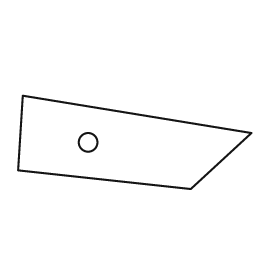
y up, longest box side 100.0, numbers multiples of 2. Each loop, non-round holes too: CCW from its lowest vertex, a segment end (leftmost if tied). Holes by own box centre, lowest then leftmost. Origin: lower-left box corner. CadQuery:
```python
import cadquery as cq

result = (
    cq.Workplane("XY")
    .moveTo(74.0, 0.0)
    .lineTo(100.0, 24.0)
    .lineTo(2.0, 40.0)
    .lineTo(0.0, 8.0)
    .close()
    .moveTo(30.0, 20.0)
    .circle(4.0)
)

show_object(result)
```